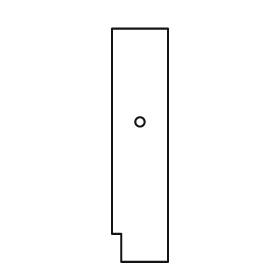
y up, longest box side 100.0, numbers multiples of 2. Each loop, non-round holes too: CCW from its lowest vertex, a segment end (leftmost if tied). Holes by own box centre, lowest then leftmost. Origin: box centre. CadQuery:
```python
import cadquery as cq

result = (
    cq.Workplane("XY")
    .moveTo(-8.0, -50.0)
    .lineTo(12.0, -50.0)
    .lineTo(12.0, 50.0)
    .lineTo(-12.0, 50.0)
    .lineTo(-12.0, -38.0)
    .lineTo(-8.0, -38.0)
    .close()
    .moveTo(0.0, 10.0)
    .circle(2.0)
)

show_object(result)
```